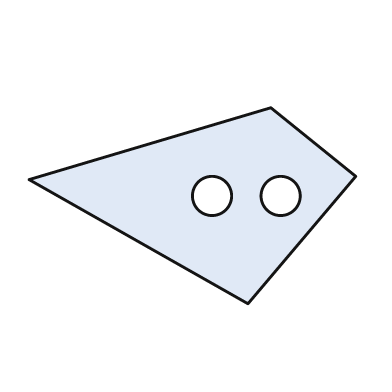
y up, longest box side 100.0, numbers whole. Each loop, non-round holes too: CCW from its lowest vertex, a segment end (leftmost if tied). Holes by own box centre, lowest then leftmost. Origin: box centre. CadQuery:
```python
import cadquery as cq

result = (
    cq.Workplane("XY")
    .moveTo(17.0, -30.0)
    .lineTo(50.0, 9.0)
    .lineTo(24.0, 30.0)
    .lineTo(-50.0, 8.0)
    .close()
    .moveTo(6.0, 3.0)
    .circle(6.0)
    .moveTo(27.0, 3.0)
    .circle(6.0)
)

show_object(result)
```